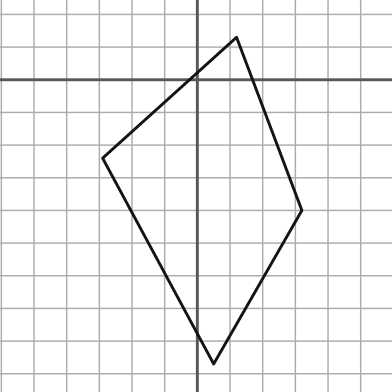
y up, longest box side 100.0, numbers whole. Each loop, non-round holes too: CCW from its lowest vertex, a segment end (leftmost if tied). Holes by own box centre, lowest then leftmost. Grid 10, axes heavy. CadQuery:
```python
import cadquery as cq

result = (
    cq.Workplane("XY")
    .moveTo(5.0, -87.0)
    .lineTo(32.0, -40.0)
    .lineTo(12.0, 13.0)
    .lineTo(-29.0, -24.0)
    .close()
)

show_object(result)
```